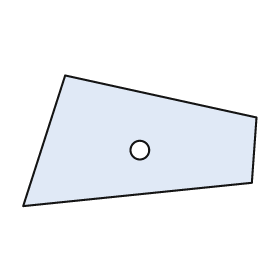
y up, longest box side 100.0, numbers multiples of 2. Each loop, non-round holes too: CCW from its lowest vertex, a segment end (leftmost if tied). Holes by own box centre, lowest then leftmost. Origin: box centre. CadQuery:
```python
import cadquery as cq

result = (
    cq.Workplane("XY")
    .moveTo(-50.0, -28.0)
    .lineTo(48.0, -18.0)
    .lineTo(50.0, 10.0)
    .lineTo(-32.0, 28.0)
    .close()
    .moveTo(0.0, -4.0)
    .circle(4.0)
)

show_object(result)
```